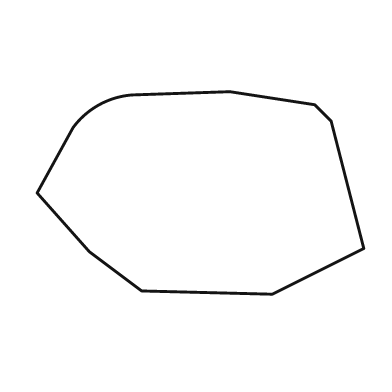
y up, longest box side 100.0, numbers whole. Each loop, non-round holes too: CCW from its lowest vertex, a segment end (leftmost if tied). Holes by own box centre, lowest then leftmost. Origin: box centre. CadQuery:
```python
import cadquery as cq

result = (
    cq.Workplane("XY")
    .moveTo(22.0, -31.0)
    .lineTo(50.0, -17.0)
    .lineTo(40.0, 22.0)
    .lineTo(35.0, 27.0)
    .lineTo(9.0, 31.0)
    .lineTo(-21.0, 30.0)
    .threePointArc((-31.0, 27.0), (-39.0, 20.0))
    .lineTo(-50.0, 0.0)
    .lineTo(-34.0, -18.0)
    .lineTo(-18.0, -30.0)
    .close()
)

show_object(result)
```